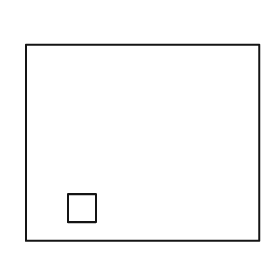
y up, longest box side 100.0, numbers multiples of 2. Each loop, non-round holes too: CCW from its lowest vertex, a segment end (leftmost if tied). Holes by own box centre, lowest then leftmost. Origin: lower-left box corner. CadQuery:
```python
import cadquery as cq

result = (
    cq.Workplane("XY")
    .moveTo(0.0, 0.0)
    .lineTo(100.0, 0.0)
    .lineTo(100.0, 84.0)
    .lineTo(0.0, 84.0)
    .close()
    .moveTo(18.0, 8.0)
    .lineTo(30.0, 8.0)
    .lineTo(30.0, 20.0)
    .lineTo(18.0, 20.0)
    .close()
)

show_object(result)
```